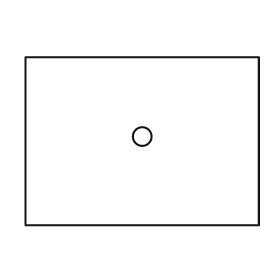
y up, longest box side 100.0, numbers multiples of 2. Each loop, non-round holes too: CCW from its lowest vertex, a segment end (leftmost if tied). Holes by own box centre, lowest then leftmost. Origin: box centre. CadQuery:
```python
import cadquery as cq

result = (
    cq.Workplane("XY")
    .moveTo(-50.0, -36.0)
    .lineTo(50.0, -36.0)
    .lineTo(50.0, 36.0)
    .lineTo(-50.0, 36.0)
    .close()
    .moveTo(0.0, 2.0)
    .circle(4.0)
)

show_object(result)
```